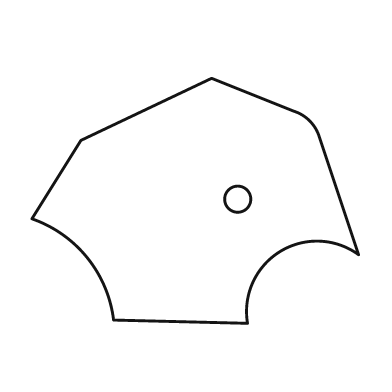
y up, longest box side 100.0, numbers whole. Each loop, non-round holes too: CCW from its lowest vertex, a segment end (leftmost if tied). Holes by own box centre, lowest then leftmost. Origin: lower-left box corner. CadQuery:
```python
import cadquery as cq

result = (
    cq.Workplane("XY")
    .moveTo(66.0, 0.0)
    .threePointArc((76.0, 22.0), (100.0, 21.0))
    .lineTo(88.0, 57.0)
    .threePointArc((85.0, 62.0), (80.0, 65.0))
    .lineTo(55.0, 75.0)
    .lineTo(15.0, 56.0)
    .lineTo(0.0, 32.0)
    .threePointArc((17.0, 20.0), (25.0, 1.0))
    .close()
    .moveTo(63.0, 38.0)
    .circle(4.0)
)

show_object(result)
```